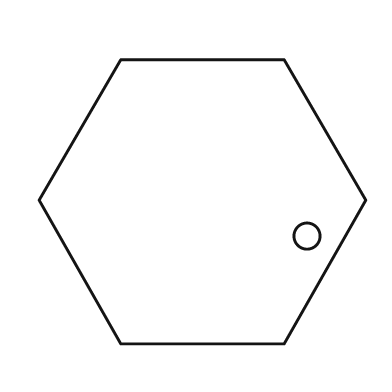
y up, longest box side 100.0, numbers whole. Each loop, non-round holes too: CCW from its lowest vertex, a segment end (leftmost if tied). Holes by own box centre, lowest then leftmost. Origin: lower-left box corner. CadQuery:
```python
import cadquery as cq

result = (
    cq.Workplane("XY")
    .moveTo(25.0, 0.0)
    .lineTo(75.0, 0.0)
    .lineTo(100.0, 44.0)
    .lineTo(75.0, 87.0)
    .lineTo(25.0, 87.0)
    .lineTo(0.0, 44.0)
    .close()
    .moveTo(82.0, 33.0)
    .circle(4.0)
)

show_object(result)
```